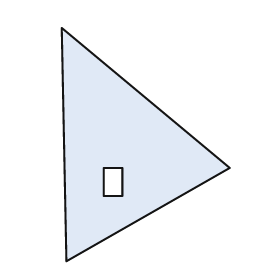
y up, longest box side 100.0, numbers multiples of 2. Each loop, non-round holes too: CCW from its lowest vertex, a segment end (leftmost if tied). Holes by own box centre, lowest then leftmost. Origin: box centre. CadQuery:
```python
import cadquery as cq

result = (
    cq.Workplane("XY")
    .moveTo(-34.0, -50.0)
    .lineTo(36.0, -10.0)
    .lineTo(-36.0, 50.0)
    .close()
    .moveTo(-18.0, -22.0)
    .lineTo(-10.0, -22.0)
    .lineTo(-10.0, -10.0)
    .lineTo(-18.0, -10.0)
    .close()
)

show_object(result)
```